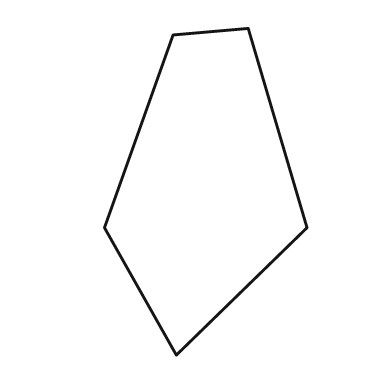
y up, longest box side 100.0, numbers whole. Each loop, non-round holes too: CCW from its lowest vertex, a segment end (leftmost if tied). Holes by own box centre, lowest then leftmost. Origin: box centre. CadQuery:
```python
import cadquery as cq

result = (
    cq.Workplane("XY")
    .moveTo(-9.0, -50.0)
    .lineTo(31.0, -11.0)
    .lineTo(13.0, 50.0)
    .lineTo(-10.0, 48.0)
    .lineTo(-31.0, -11.0)
    .close()
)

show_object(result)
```